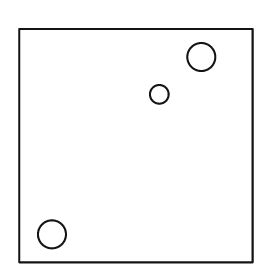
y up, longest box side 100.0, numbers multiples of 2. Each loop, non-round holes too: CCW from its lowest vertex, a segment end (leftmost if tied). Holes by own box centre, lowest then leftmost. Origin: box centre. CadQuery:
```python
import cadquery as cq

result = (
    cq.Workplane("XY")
    .moveTo(-50.0, -50.0)
    .lineTo(50.0, -50.0)
    .lineTo(50.0, 50.0)
    .lineTo(-50.0, 50.0)
    .close()
    .moveTo(-36.0, -38.0)
    .circle(6.0)
    .moveTo(10.0, 22.0)
    .circle(4.0)
    .moveTo(28.0, 38.0)
    .circle(6.0)
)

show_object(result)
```